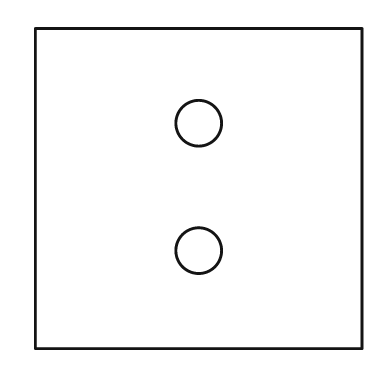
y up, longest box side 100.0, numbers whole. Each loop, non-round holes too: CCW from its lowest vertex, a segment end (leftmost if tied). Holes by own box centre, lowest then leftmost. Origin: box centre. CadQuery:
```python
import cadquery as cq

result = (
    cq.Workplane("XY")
    .moveTo(-50.0, -49.0)
    .lineTo(50.0, -49.0)
    .lineTo(50.0, 49.0)
    .lineTo(-50.0, 49.0)
    .close()
    .moveTo(0.0, -19.0)
    .circle(7.0)
    .moveTo(0.0, 20.0)
    .circle(7.0)
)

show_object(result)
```